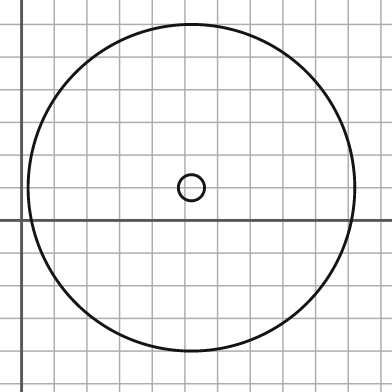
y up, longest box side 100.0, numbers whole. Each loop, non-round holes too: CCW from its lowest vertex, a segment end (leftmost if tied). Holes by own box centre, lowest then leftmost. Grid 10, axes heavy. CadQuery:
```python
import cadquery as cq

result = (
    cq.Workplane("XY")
    .moveTo(52.0, 10.0)
    .circle(50.0)
    .moveTo(52.0, 10.0)
    .circle(4.0)
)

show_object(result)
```